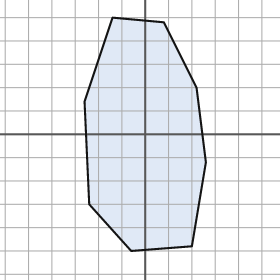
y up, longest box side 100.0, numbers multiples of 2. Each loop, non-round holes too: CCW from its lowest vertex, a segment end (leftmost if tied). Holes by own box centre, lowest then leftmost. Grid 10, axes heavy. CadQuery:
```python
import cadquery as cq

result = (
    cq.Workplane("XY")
    .moveTo(-6.0, -50.0)
    .lineTo(20.0, -48.0)
    .lineTo(26.0, -12.0)
    .lineTo(22.0, 20.0)
    .lineTo(8.0, 48.0)
    .lineTo(-14.0, 50.0)
    .lineTo(-26.0, 14.0)
    .lineTo(-24.0, -30.0)
    .close()
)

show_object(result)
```